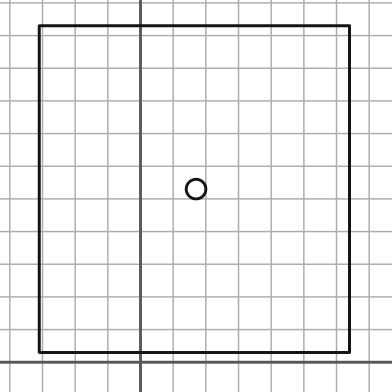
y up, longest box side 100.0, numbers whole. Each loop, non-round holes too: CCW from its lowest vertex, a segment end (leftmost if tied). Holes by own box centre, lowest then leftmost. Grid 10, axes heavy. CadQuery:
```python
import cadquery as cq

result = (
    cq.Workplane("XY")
    .moveTo(-31.0, 3.0)
    .lineTo(64.0, 3.0)
    .lineTo(64.0, 103.0)
    .lineTo(-31.0, 103.0)
    .close()
    .moveTo(17.0, 53.0)
    .circle(3.0)
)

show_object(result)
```